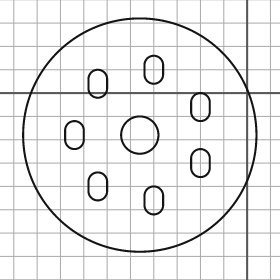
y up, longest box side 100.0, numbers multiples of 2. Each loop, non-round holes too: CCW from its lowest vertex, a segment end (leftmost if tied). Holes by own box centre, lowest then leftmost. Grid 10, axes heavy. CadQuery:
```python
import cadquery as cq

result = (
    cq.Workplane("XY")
    .moveTo(-46.0, -18.0)
    .circle(50.0)
    .moveTo(-44.0, -48.0)
    .threePointArc((-40.0, -52.0), (-36.0, -48.0))
    .lineTo(-36.0, -44.0)
    .threePointArc((-40.0, -40.0), (-44.0, -44.0))
    .close()
    .moveTo(-68.0, -42.0)
    .threePointArc((-64.0, -46.0), (-60.0, -42.0))
    .lineTo(-60.0, -38.0)
    .threePointArc((-64.0, -34.0), (-68.0, -38.0))
    .close()
    .moveTo(-24.0, -32.0)
    .threePointArc((-20.0, -36.0), (-16.0, -32.0))
    .lineTo(-16.0, -28.0)
    .threePointArc((-20.0, -24.0), (-24.0, -28.0))
    .close()
    .moveTo(-78.0, -20.0)
    .threePointArc((-74.0, -24.0), (-70.0, -20.0))
    .lineTo(-70.0, -16.0)
    .threePointArc((-74.0, -12.0), (-78.0, -16.0))
    .close()
    .moveTo(-46.0, -18.0)
    .circle(8.0)
    .moveTo(-24.0, -8.0)
    .threePointArc((-20.0, -12.0), (-16.0, -8.0))
    .lineTo(-16.0, -4.0)
    .threePointArc((-20.0, 0.0), (-24.0, -4.0))
    .close()
    .moveTo(-68.0, 2.0)
    .threePointArc((-64.0, -2.0), (-60.0, 2.0))
    .lineTo(-60.0, 6.0)
    .threePointArc((-64.0, 10.0), (-68.0, 6.0))
    .close()
    .moveTo(-44.0, 8.0)
    .threePointArc((-40.0, 4.0), (-36.0, 8.0))
    .lineTo(-36.0, 12.0)
    .threePointArc((-40.0, 16.0), (-44.0, 12.0))
    .close()
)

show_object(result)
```